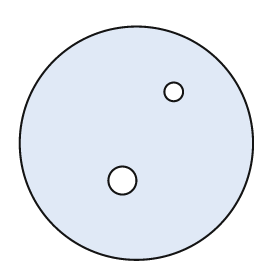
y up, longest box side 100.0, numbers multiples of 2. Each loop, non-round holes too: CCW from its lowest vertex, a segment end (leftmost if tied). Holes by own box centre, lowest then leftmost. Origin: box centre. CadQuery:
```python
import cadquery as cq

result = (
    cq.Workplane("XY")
    .moveTo(0.0, 0.0)
    .circle(50.0)
    .moveTo(-6.0, -16.0)
    .circle(6.0)
    .moveTo(16.0, 22.0)
    .circle(4.0)
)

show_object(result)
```